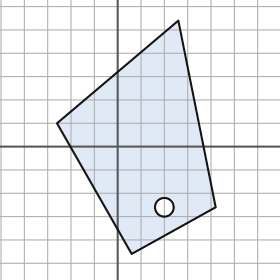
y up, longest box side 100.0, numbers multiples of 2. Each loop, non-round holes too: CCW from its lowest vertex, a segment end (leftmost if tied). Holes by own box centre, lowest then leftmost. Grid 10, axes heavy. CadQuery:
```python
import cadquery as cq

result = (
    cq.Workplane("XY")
    .moveTo(6.0, -46.0)
    .lineTo(42.0, -26.0)
    .lineTo(26.0, 54.0)
    .lineTo(-26.0, 10.0)
    .close()
    .moveTo(20.0, -26.0)
    .circle(4.0)
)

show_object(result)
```